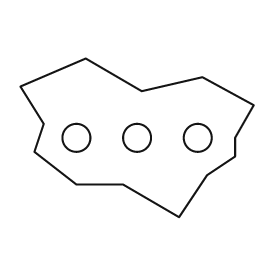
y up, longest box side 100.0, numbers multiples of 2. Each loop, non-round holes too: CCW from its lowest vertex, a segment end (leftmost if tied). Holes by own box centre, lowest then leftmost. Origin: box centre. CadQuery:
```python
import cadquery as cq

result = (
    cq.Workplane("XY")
    .moveTo(18.0, -34.0)
    .lineTo(30.0, -16.0)
    .lineTo(42.0, -8.0)
    .lineTo(42.0, 0.0)
    .lineTo(50.0, 14.0)
    .lineTo(28.0, 26.0)
    .lineTo(2.0, 20.0)
    .lineTo(-22.0, 34.0)
    .lineTo(-50.0, 22.0)
    .lineTo(-40.0, 6.0)
    .lineTo(-44.0, -6.0)
    .lineTo(-26.0, -20.0)
    .lineTo(-6.0, -20.0)
    .close()
    .moveTo(-26.0, 0.0)
    .circle(6.0)
    .moveTo(0.0, 0.0)
    .circle(6.0)
    .moveTo(26.0, 0.0)
    .circle(6.0)
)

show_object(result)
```